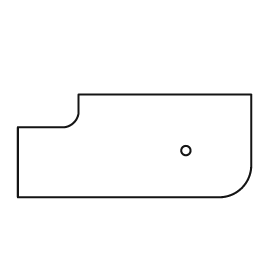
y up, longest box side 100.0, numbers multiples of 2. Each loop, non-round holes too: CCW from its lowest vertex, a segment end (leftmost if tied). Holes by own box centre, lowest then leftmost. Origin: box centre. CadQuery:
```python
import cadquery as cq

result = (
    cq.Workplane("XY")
    .moveTo(-50.0, -22.0)
    .lineTo(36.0, -22.0)
    .threePointArc((46.0, -18.0), (50.0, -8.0))
    .lineTo(50.0, 22.0)
    .lineTo(-24.0, 22.0)
    .lineTo(-24.0, 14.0)
    .threePointArc((-26.0, 10.0), (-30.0, 8.0))
    .lineTo(-50.0, 8.0)
    .close()
    .moveTo(22.0, -2.0)
    .circle(2.0)
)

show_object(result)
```